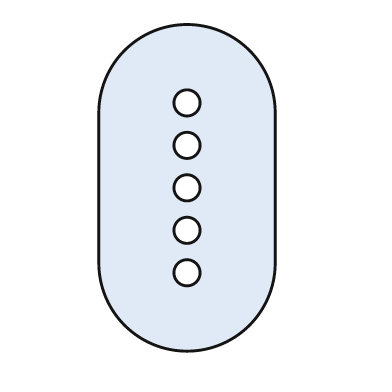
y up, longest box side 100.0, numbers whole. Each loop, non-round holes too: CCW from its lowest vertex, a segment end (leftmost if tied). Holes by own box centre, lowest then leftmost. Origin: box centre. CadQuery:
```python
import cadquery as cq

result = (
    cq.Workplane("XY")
    .moveTo(-27.0, -23.0)
    .threePointArc((0.0, -50.0), (27.0, -23.0))
    .lineTo(27.0, 23.0)
    .threePointArc((0.0, 50.0), (-27.0, 23.0))
    .close()
    .moveTo(0.0, -26.0)
    .circle(4.0)
    .moveTo(0.0, -13.0)
    .circle(4.0)
    .moveTo(0.0, 0.0)
    .circle(4.0)
    .moveTo(0.0, 13.0)
    .circle(4.0)
    .moveTo(0.0, 26.0)
    .circle(4.0)
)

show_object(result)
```